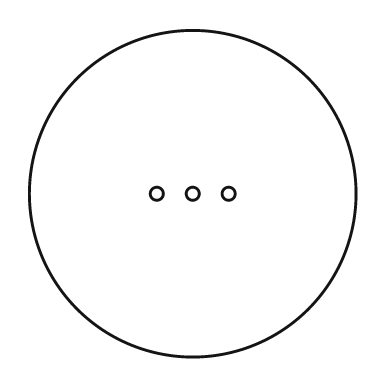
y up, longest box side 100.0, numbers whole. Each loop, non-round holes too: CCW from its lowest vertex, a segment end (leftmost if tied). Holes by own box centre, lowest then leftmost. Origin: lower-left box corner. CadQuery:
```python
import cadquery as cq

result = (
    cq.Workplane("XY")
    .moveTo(50.0, 50.0)
    .circle(50.0)
    .moveTo(39.0, 50.0)
    .circle(2.0)
    .moveTo(50.0, 50.0)
    .circle(2.0)
    .moveTo(61.0, 50.0)
    .circle(2.0)
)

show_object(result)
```